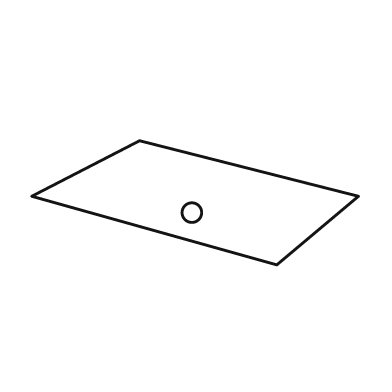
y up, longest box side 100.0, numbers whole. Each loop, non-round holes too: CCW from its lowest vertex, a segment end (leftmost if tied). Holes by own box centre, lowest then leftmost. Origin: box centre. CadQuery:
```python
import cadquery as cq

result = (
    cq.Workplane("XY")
    .moveTo(25.0, -19.0)
    .lineTo(50.0, 2.0)
    .lineTo(-17.0, 19.0)
    .lineTo(-50.0, 2.0)
    .close()
    .moveTo(-1.0, -3.0)
    .circle(3.0)
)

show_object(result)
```